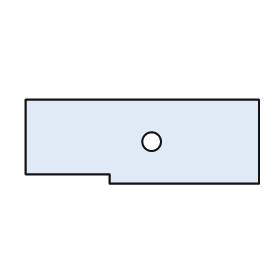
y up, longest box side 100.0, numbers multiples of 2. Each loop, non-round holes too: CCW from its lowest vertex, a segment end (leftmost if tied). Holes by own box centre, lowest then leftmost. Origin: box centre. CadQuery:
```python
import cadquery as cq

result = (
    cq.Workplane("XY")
    .moveTo(-14.0, -18.0)
    .lineTo(50.0, -18.0)
    .lineTo(50.0, 18.0)
    .lineTo(-50.0, 18.0)
    .lineTo(-50.0, -14.0)
    .lineTo(-14.0, -14.0)
    .close()
    .moveTo(4.0, 0.0)
    .circle(4.0)
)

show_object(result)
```